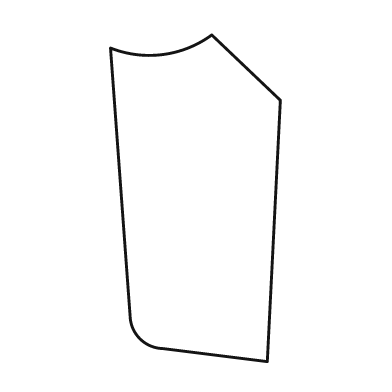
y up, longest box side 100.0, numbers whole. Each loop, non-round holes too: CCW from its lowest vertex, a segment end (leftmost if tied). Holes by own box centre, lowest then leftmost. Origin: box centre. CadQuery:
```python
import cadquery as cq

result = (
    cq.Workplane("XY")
    .moveTo(22.0, -50.0)
    .lineTo(26.0, 30.0)
    .lineTo(5.0, 50.0)
    .threePointArc((-10.0, 44.0), (-26.0, 46.0))
    .lineTo(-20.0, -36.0)
    .threePointArc((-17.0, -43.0), (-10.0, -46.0))
    .close()
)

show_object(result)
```